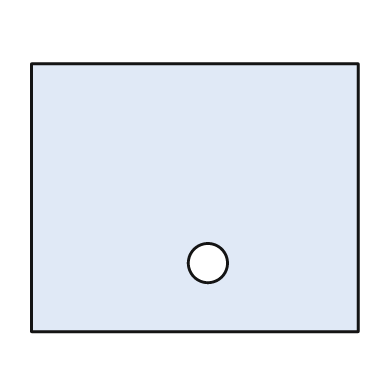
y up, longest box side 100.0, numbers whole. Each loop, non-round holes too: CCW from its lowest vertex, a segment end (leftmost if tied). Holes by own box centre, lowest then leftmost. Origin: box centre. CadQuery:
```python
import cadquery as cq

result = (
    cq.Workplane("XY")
    .moveTo(-50.0, -41.0)
    .lineTo(50.0, -41.0)
    .lineTo(50.0, 41.0)
    .lineTo(-50.0, 41.0)
    .close()
    .moveTo(4.0, -20.0)
    .circle(6.0)
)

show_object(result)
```